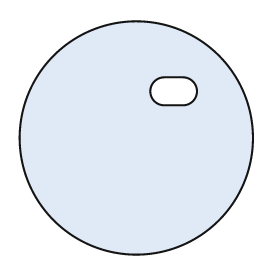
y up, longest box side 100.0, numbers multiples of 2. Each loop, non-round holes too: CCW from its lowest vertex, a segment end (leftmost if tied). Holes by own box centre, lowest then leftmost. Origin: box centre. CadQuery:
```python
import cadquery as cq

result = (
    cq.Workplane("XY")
    .moveTo(0.0, 0.0)
    .circle(50.0)
    .moveTo(12.0, 14.0)
    .lineTo(20.0, 14.0)
    .threePointArc((26.0, 20.0), (20.0, 26.0))
    .lineTo(12.0, 26.0)
    .threePointArc((6.0, 20.0), (12.0, 14.0))
    .close()
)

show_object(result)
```